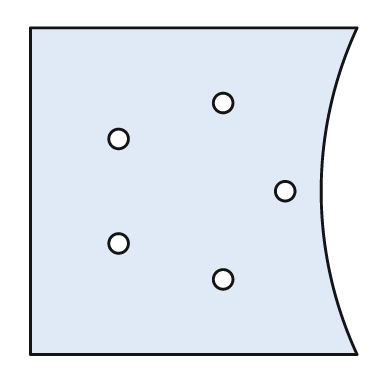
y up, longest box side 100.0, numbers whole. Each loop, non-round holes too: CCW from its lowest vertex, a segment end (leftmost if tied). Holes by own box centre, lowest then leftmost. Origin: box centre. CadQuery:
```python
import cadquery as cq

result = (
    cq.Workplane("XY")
    .moveTo(-50.0, -50.0)
    .lineTo(50.0, -50.0)
    .threePointArc((39.0, 0.0), (50.0, 50.0))
    .lineTo(-50.0, 50.0)
    .close()
    .moveTo(9.0, -27.0)
    .circle(3.0)
    .moveTo(-23.0, -16.0)
    .circle(3.0)
    .moveTo(28.0, 0.0)
    .circle(3.0)
    .moveTo(-23.0, 16.0)
    .circle(3.0)
    .moveTo(9.0, 27.0)
    .circle(3.0)
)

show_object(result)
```